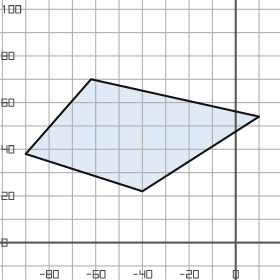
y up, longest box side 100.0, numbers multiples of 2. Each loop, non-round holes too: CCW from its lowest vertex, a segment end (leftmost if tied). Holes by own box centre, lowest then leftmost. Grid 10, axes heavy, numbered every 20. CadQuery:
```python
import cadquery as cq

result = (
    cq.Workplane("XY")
    .moveTo(-40.0, 22.0)
    .lineTo(10.0, 54.0)
    .lineTo(-62.0, 70.0)
    .lineTo(-90.0, 38.0)
    .close()
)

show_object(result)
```